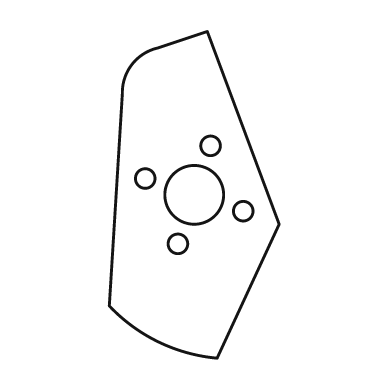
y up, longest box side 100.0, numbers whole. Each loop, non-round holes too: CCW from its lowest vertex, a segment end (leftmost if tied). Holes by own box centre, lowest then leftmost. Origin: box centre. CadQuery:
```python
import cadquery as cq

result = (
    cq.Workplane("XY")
    .moveTo(7.0, -50.0)
    .lineTo(26.0, -9.0)
    .lineTo(4.0, 50.0)
    .lineTo(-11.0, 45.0)
    .threePointArc((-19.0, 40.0), (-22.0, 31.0))
    .lineTo(-26.0, -34.0)
    .threePointArc((-11.0, -45.0), (7.0, -50.0))
    .close()
    .moveTo(-5.0, -15.0)
    .circle(3.0)
    .moveTo(15.0, -5.0)
    .circle(3.0)
    .moveTo(0.0, 0.0)
    .circle(9.0)
    .moveTo(-15.0, 5.0)
    .circle(3.0)
    .moveTo(5.0, 15.0)
    .circle(3.0)
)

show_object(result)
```